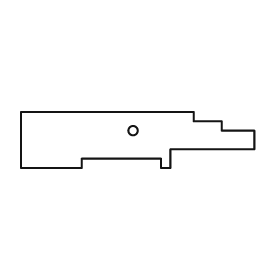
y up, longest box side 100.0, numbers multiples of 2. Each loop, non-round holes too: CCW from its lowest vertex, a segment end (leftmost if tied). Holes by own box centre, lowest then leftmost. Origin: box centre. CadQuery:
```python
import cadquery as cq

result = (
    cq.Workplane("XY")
    .moveTo(-50.0, -12.0)
    .lineTo(-24.0, -12.0)
    .lineTo(-24.0, -8.0)
    .lineTo(10.0, -8.0)
    .lineTo(10.0, -12.0)
    .lineTo(14.0, -12.0)
    .lineTo(14.0, -4.0)
    .lineTo(50.0, -4.0)
    .lineTo(50.0, 4.0)
    .lineTo(36.0, 4.0)
    .lineTo(36.0, 8.0)
    .lineTo(24.0, 8.0)
    .lineTo(24.0, 12.0)
    .lineTo(-50.0, 12.0)
    .close()
    .moveTo(-2.0, 4.0)
    .circle(2.0)
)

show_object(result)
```